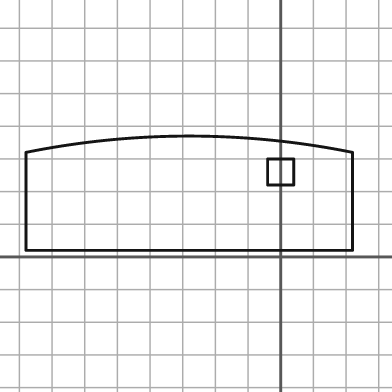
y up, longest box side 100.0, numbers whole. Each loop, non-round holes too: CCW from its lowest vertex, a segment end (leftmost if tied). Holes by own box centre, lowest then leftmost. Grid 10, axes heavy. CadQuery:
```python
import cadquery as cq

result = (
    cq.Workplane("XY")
    .moveTo(-78.0, 2.0)
    .lineTo(22.0, 2.0)
    .lineTo(22.0, 32.0)
    .threePointArc((-28.0, 37.0), (-78.0, 32.0))
    .close()
    .moveTo(-4.0, 22.0)
    .lineTo(4.0, 22.0)
    .lineTo(4.0, 30.0)
    .lineTo(-4.0, 30.0)
    .close()
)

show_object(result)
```